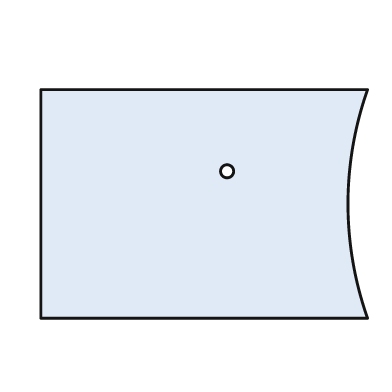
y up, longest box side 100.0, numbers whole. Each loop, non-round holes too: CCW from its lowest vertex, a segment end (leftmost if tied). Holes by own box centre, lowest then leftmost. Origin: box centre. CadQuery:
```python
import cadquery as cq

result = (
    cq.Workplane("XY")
    .moveTo(-50.0, -35.0)
    .lineTo(50.0, -35.0)
    .threePointArc((44.0, 0.0), (50.0, 35.0))
    .lineTo(-50.0, 35.0)
    .close()
    .moveTo(7.0, 10.0)
    .circle(2.0)
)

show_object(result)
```